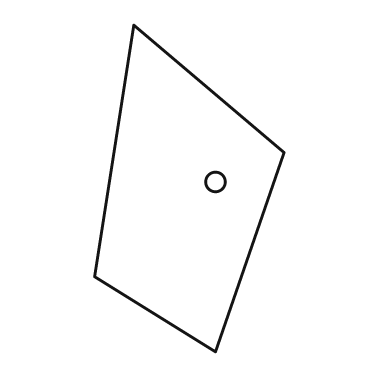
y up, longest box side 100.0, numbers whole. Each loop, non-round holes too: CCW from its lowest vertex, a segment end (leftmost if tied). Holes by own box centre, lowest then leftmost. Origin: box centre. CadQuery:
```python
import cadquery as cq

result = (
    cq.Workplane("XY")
    .moveTo(8.0, -50.0)
    .lineTo(29.0, 11.0)
    .lineTo(-17.0, 50.0)
    .lineTo(-29.0, -27.0)
    .close()
    .moveTo(8.0, 2.0)
    .circle(3.0)
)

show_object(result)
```